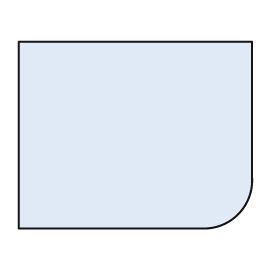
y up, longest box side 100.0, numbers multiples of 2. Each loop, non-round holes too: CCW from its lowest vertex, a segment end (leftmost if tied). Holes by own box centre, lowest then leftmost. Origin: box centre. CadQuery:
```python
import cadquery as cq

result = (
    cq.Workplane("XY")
    .moveTo(-50.0, -40.0)
    .lineTo(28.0, -40.0)
    .threePointArc((44.0, -34.0), (50.0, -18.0))
    .lineTo(50.0, 40.0)
    .lineTo(-50.0, 40.0)
    .close()
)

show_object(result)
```